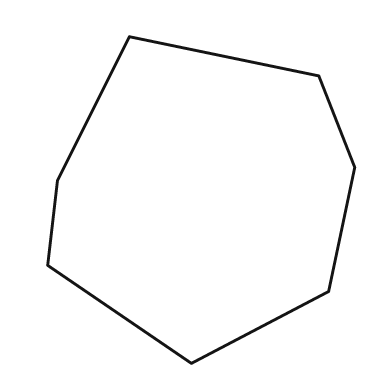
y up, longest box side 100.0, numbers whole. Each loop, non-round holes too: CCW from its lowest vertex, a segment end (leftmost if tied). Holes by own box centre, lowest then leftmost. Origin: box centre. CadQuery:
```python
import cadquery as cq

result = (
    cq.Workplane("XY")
    .moveTo(-3.0, -50.0)
    .lineTo(39.0, -28.0)
    .lineTo(47.0, 10.0)
    .lineTo(36.0, 38.0)
    .lineTo(-22.0, 50.0)
    .lineTo(-44.0, 6.0)
    .lineTo(-47.0, -20.0)
    .close()
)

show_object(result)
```